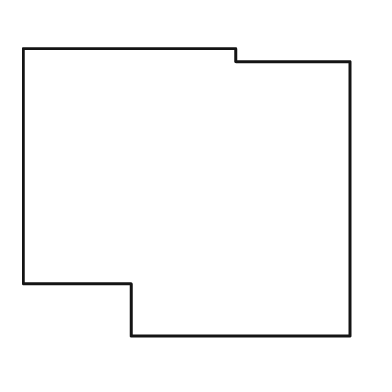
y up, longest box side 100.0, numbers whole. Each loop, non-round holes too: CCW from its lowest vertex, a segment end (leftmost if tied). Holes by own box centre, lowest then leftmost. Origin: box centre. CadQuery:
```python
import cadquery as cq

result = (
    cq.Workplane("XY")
    .moveTo(-17.0, -44.0)
    .lineTo(50.0, -44.0)
    .lineTo(50.0, 40.0)
    .lineTo(15.0, 40.0)
    .lineTo(15.0, 44.0)
    .lineTo(-50.0, 44.0)
    .lineTo(-50.0, -28.0)
    .lineTo(-17.0, -28.0)
    .close()
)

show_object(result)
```